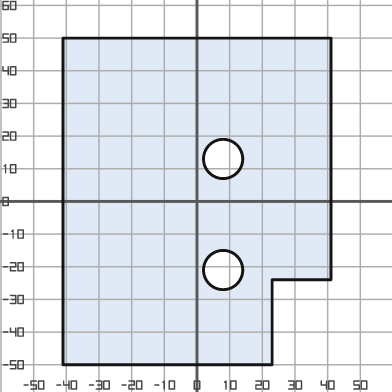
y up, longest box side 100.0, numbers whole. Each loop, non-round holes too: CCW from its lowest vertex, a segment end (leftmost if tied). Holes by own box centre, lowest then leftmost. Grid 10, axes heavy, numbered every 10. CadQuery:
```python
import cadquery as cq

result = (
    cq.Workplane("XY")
    .moveTo(-41.0, -50.0)
    .lineTo(23.0, -50.0)
    .lineTo(23.0, -24.0)
    .lineTo(41.0, -24.0)
    .lineTo(41.0, 50.0)
    .lineTo(-41.0, 50.0)
    .close()
    .moveTo(8.0, -21.0)
    .circle(6.0)
    .moveTo(8.0, 13.0)
    .circle(6.0)
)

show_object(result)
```